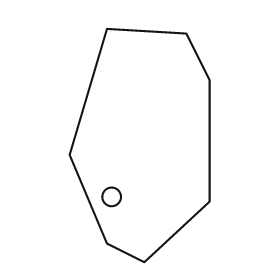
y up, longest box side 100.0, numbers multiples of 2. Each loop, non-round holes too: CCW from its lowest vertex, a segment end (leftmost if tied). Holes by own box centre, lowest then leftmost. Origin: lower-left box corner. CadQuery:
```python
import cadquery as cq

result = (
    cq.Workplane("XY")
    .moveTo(32.0, 0.0)
    .lineTo(60.0, 26.0)
    .lineTo(60.0, 78.0)
    .lineTo(50.0, 98.0)
    .lineTo(16.0, 100.0)
    .lineTo(0.0, 46.0)
    .lineTo(16.0, 8.0)
    .close()
    .moveTo(18.0, 28.0)
    .circle(4.0)
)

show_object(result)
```